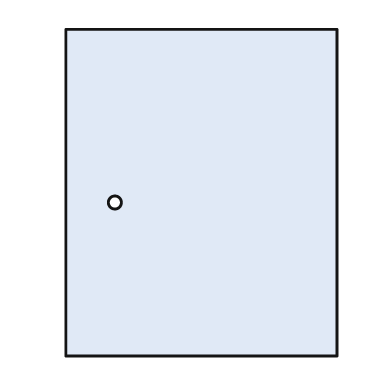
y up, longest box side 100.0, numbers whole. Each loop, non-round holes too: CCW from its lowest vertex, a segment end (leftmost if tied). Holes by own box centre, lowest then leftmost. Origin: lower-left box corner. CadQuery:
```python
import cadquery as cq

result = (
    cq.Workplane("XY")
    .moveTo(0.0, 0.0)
    .lineTo(83.0, 0.0)
    .lineTo(83.0, 100.0)
    .lineTo(0.0, 100.0)
    .close()
    .moveTo(15.0, 47.0)
    .circle(2.0)
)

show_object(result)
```